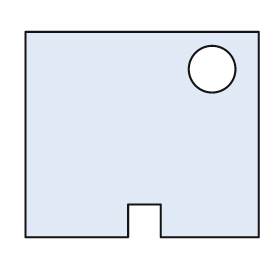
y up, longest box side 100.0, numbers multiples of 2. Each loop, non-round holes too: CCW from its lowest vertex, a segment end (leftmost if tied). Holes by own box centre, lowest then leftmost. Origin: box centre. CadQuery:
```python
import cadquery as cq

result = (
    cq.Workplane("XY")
    .moveTo(-50.0, -44.0)
    .lineTo(-6.0, -44.0)
    .lineTo(-6.0, -30.0)
    .lineTo(8.0, -30.0)
    .lineTo(8.0, -44.0)
    .lineTo(50.0, -44.0)
    .lineTo(50.0, 44.0)
    .lineTo(-50.0, 44.0)
    .close()
    .moveTo(30.0, 28.0)
    .circle(10.0)
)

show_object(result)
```